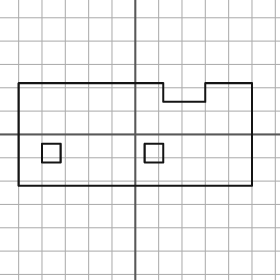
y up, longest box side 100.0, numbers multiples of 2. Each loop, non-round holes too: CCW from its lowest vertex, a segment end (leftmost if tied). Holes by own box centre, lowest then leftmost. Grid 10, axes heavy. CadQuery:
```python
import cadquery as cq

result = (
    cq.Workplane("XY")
    .moveTo(-50.0, -22.0)
    .lineTo(50.0, -22.0)
    .lineTo(50.0, 22.0)
    .lineTo(30.0, 22.0)
    .lineTo(30.0, 14.0)
    .lineTo(12.0, 14.0)
    .lineTo(12.0, 22.0)
    .lineTo(-50.0, 22.0)
    .close()
    .moveTo(-40.0, -12.0)
    .lineTo(-32.0, -12.0)
    .lineTo(-32.0, -4.0)
    .lineTo(-40.0, -4.0)
    .close()
    .moveTo(4.0, -12.0)
    .lineTo(12.0, -12.0)
    .lineTo(12.0, -4.0)
    .lineTo(4.0, -4.0)
    .close()
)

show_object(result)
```